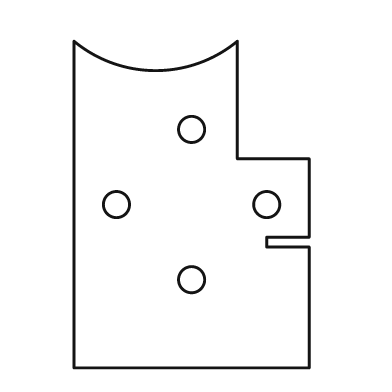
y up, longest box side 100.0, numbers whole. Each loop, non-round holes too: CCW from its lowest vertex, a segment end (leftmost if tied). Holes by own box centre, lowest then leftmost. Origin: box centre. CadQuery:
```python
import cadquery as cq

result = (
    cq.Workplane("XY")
    .moveTo(-36.0, -50.0)
    .lineTo(36.0, -50.0)
    .lineTo(36.0, -13.0)
    .lineTo(23.0, -13.0)
    .lineTo(23.0, -10.0)
    .lineTo(36.0, -10.0)
    .lineTo(36.0, 14.0)
    .lineTo(14.0, 14.0)
    .lineTo(14.0, 50.0)
    .threePointArc((-11.0, 41.0), (-36.0, 50.0))
    .close()
    .moveTo(0.0, -23.0)
    .circle(4.0)
    .moveTo(-23.0, 0.0)
    .circle(4.0)
    .moveTo(23.0, 0.0)
    .circle(4.0)
    .moveTo(0.0, 23.0)
    .circle(4.0)
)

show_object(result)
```